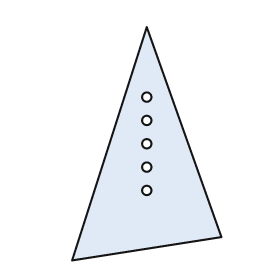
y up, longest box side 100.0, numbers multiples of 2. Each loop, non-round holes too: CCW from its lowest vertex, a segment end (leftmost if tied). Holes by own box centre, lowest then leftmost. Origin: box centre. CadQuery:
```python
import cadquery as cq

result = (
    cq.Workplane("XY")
    .moveTo(-32.0, -50.0)
    .lineTo(32.0, -40.0)
    .lineTo(0.0, 50.0)
    .close()
    .moveTo(0.0, -20.0)
    .circle(2.0)
    .moveTo(0.0, -10.0)
    .circle(2.0)
    .moveTo(0.0, 0.0)
    .circle(2.0)
    .moveTo(0.0, 10.0)
    .circle(2.0)
    .moveTo(0.0, 20.0)
    .circle(2.0)
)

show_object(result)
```